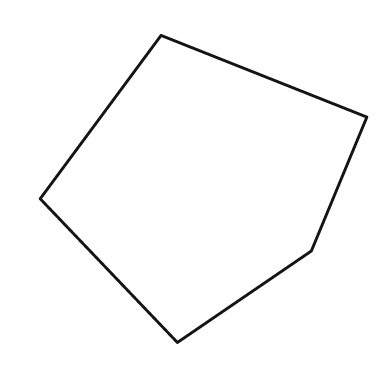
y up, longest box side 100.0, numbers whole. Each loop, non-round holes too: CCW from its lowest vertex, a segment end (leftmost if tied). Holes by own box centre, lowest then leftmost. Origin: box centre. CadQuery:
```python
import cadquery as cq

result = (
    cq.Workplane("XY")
    .moveTo(-8.0, -47.0)
    .lineTo(33.0, -19.0)
    .lineTo(50.0, 22.0)
    .lineTo(-13.0, 47.0)
    .lineTo(-50.0, -3.0)
    .close()
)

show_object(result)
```